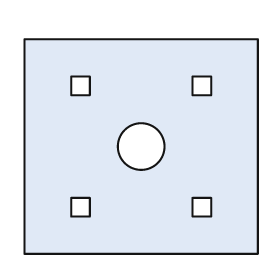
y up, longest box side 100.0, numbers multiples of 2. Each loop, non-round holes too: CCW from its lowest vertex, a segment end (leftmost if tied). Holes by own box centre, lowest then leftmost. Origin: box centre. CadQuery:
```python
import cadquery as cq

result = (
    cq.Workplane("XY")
    .moveTo(-50.0, -46.0)
    .lineTo(50.0, -46.0)
    .lineTo(50.0, 46.0)
    .lineTo(-50.0, 46.0)
    .close()
    .moveTo(-30.0, -30.0)
    .lineTo(-22.0, -30.0)
    .lineTo(-22.0, -22.0)
    .lineTo(-30.0, -22.0)
    .close()
    .moveTo(22.0, -30.0)
    .lineTo(30.0, -30.0)
    .lineTo(30.0, -22.0)
    .lineTo(22.0, -22.0)
    .close()
    .moveTo(0.0, 0.0)
    .circle(10.0)
    .moveTo(-30.0, 22.0)
    .lineTo(-22.0, 22.0)
    .lineTo(-22.0, 30.0)
    .lineTo(-30.0, 30.0)
    .close()
    .moveTo(22.0, 22.0)
    .lineTo(30.0, 22.0)
    .lineTo(30.0, 30.0)
    .lineTo(22.0, 30.0)
    .close()
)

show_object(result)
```